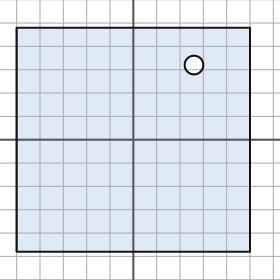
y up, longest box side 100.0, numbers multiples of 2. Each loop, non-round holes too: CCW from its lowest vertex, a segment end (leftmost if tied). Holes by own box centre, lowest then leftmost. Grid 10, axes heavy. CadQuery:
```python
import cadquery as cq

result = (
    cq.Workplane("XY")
    .moveTo(-50.0, -48.0)
    .lineTo(50.0, -48.0)
    .lineTo(50.0, 48.0)
    .lineTo(-50.0, 48.0)
    .close()
    .moveTo(26.0, 32.0)
    .circle(4.0)
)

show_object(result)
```